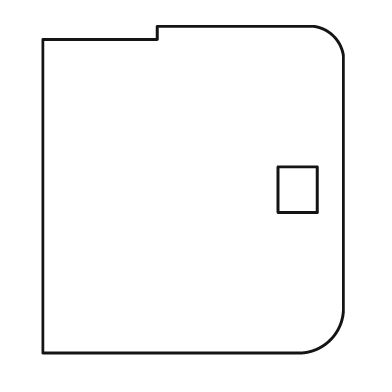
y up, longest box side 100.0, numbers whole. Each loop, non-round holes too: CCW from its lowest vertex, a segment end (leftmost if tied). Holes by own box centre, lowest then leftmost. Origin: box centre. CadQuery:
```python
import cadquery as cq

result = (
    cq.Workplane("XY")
    .moveTo(-46.0, -50.0)
    .lineTo(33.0, -50.0)
    .threePointArc((42.0, -46.0), (46.0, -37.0))
    .lineTo(46.0, 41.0)
    .threePointArc((43.0, 47.0), (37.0, 50.0))
    .lineTo(-11.0, 50.0)
    .lineTo(-11.0, 46.0)
    .lineTo(-46.0, 46.0)
    .close()
    .moveTo(26.0, -7.0)
    .lineTo(38.0, -7.0)
    .lineTo(38.0, 7.0)
    .lineTo(26.0, 7.0)
    .close()
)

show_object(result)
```